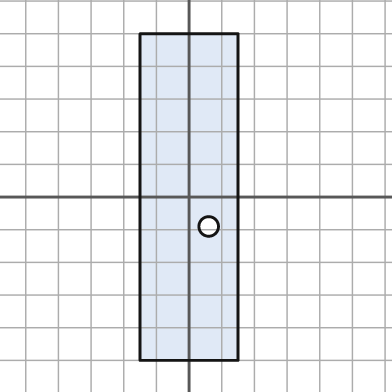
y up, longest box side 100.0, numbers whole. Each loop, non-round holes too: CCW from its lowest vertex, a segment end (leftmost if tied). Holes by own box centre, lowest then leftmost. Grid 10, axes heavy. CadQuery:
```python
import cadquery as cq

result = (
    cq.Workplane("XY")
    .moveTo(-15.0, -50.0)
    .lineTo(15.0, -50.0)
    .lineTo(15.0, 50.0)
    .lineTo(-15.0, 50.0)
    .close()
    .moveTo(6.0, -9.0)
    .circle(3.0)
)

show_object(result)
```